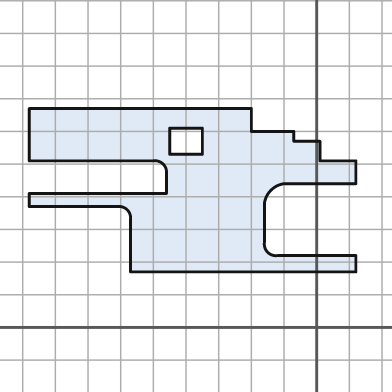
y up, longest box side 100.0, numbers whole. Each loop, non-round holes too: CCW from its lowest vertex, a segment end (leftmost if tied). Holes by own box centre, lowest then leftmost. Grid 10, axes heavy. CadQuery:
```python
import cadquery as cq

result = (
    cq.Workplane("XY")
    .moveTo(-57.0, 17.0)
    .lineTo(12.0, 17.0)
    .lineTo(12.0, 22.0)
    .lineTo(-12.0, 22.0)
    .threePointArc((-15.0, 23.0), (-16.0, 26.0))
    .lineTo(-16.0, 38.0)
    .threePointArc((-14.0, 42.0), (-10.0, 44.0))
    .lineTo(12.0, 44.0)
    .lineTo(12.0, 51.0)
    .lineTo(1.0, 51.0)
    .lineTo(1.0, 57.0)
    .lineTo(-7.0, 57.0)
    .lineTo(-7.0, 60.0)
    .lineTo(-20.0, 60.0)
    .lineTo(-20.0, 67.0)
    .lineTo(-88.0, 67.0)
    .lineTo(-88.0, 51.0)
    .lineTo(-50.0, 51.0)
    .threePointArc((-47.0, 50.0), (-46.0, 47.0))
    .lineTo(-46.0, 41.0)
    .lineTo(-88.0, 41.0)
    .lineTo(-88.0, 37.0)
    .lineTo(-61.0, 37.0)
    .threePointArc((-58.0, 36.0), (-57.0, 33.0))
    .close()
    .moveTo(-45.0, 53.0)
    .lineTo(-35.0, 53.0)
    .lineTo(-35.0, 61.0)
    .lineTo(-45.0, 61.0)
    .close()
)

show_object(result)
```